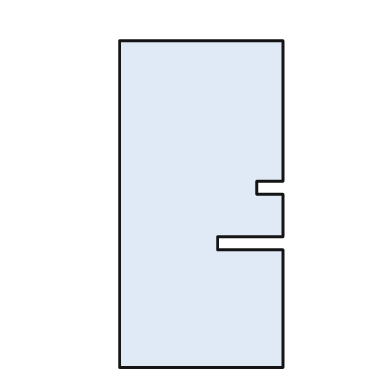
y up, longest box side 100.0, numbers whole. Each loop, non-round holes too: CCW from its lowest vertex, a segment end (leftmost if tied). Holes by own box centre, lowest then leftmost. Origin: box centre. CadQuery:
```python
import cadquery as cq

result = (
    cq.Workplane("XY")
    .moveTo(-25.0, -50.0)
    .lineTo(25.0, -50.0)
    .lineTo(25.0, -14.0)
    .lineTo(5.0, -14.0)
    .lineTo(5.0, -10.0)
    .lineTo(25.0, -10.0)
    .lineTo(25.0, 3.0)
    .lineTo(17.0, 3.0)
    .lineTo(17.0, 7.0)
    .lineTo(25.0, 7.0)
    .lineTo(25.0, 50.0)
    .lineTo(-25.0, 50.0)
    .close()
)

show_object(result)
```